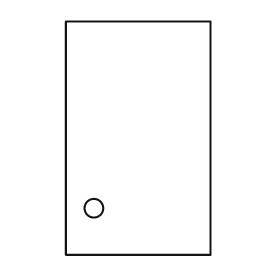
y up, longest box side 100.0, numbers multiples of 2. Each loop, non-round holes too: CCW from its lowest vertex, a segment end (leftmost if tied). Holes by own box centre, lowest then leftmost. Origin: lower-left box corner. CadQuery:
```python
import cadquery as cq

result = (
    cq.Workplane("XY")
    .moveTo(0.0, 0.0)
    .lineTo(62.0, 0.0)
    .lineTo(62.0, 100.0)
    .lineTo(0.0, 100.0)
    .close()
    .moveTo(12.0, 20.0)
    .circle(4.0)
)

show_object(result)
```